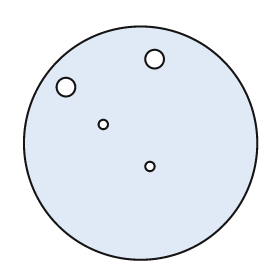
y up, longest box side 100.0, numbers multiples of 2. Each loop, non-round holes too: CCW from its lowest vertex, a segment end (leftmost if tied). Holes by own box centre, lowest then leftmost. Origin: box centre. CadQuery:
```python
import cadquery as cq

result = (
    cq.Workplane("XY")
    .moveTo(0.0, 0.0)
    .circle(50.0)
    .moveTo(4.0, -10.0)
    .circle(2.0)
    .moveTo(-16.0, 8.0)
    .circle(2.0)
    .moveTo(-32.0, 24.0)
    .circle(4.0)
    .moveTo(6.0, 36.0)
    .circle(4.0)
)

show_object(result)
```